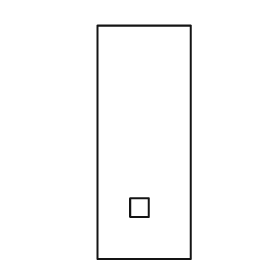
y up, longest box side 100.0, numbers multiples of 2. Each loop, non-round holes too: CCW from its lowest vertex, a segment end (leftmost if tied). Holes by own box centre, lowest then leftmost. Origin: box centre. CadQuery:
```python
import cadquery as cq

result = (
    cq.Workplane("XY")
    .moveTo(-20.0, -50.0)
    .lineTo(20.0, -50.0)
    .lineTo(20.0, 50.0)
    .lineTo(-20.0, 50.0)
    .close()
    .moveTo(-6.0, -32.0)
    .lineTo(2.0, -32.0)
    .lineTo(2.0, -24.0)
    .lineTo(-6.0, -24.0)
    .close()
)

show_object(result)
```